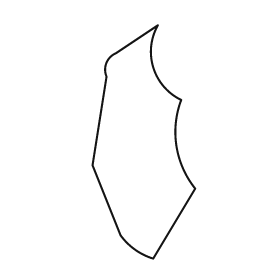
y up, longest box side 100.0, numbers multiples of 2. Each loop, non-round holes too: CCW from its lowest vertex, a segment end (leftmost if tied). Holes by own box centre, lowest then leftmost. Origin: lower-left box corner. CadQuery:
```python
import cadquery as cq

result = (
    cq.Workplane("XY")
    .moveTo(26.0, 0.0)
    .lineTo(44.0, 30.0)
    .threePointArc((36.0, 48.0), (38.0, 68.0))
    .threePointArc((26.0, 82.0), (28.0, 100.0))
    .lineTo(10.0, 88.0)
    .threePointArc((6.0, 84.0), (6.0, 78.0))
    .lineTo(0.0, 40.0)
    .lineTo(12.0, 10.0)
    .threePointArc((18.0, 4.0), (26.0, 0.0))
    .close()
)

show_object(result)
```